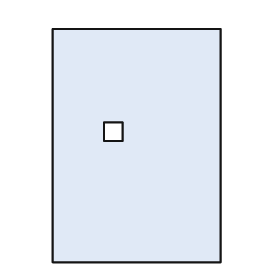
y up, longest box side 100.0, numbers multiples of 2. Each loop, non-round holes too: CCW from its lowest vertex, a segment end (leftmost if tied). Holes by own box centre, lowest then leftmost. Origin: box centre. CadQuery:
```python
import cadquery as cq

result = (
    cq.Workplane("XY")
    .moveTo(-36.0, -50.0)
    .lineTo(36.0, -50.0)
    .lineTo(36.0, 50.0)
    .lineTo(-36.0, 50.0)
    .close()
    .moveTo(-14.0, 2.0)
    .lineTo(-6.0, 2.0)
    .lineTo(-6.0, 10.0)
    .lineTo(-14.0, 10.0)
    .close()
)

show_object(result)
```